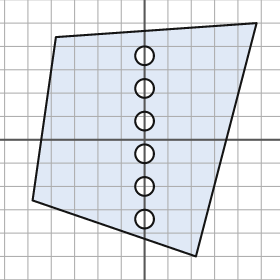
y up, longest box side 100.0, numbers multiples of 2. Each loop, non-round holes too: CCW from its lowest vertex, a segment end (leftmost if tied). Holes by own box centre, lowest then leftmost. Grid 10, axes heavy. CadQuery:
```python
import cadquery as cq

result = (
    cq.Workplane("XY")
    .moveTo(22.0, -50.0)
    .lineTo(48.0, 50.0)
    .lineTo(-38.0, 44.0)
    .lineTo(-48.0, -26.0)
    .close()
    .moveTo(0.0, -34.0)
    .circle(4.0)
    .moveTo(0.0, -20.0)
    .circle(4.0)
    .moveTo(0.0, -6.0)
    .circle(4.0)
    .moveTo(0.0, 8.0)
    .circle(4.0)
    .moveTo(0.0, 22.0)
    .circle(4.0)
    .moveTo(0.0, 36.0)
    .circle(4.0)
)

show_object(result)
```